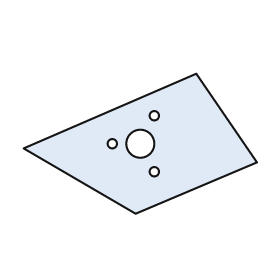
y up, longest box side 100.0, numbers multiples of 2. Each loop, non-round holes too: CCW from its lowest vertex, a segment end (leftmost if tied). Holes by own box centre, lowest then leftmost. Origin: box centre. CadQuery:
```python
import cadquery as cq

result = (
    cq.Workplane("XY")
    .moveTo(-2.0, -30.0)
    .lineTo(50.0, -8.0)
    .lineTo(24.0, 30.0)
    .lineTo(-50.0, -2.0)
    .close()
    .moveTo(6.0, -12.0)
    .circle(2.0)
    .moveTo(-12.0, 0.0)
    .circle(2.0)
    .moveTo(0.0, 0.0)
    .circle(6.0)
    .moveTo(6.0, 12.0)
    .circle(2.0)
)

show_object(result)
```